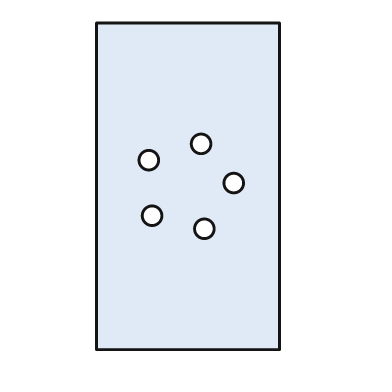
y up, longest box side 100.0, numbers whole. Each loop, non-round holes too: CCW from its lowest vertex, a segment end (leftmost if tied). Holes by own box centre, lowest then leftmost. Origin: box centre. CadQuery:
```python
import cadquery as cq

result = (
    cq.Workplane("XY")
    .moveTo(-28.0, -50.0)
    .lineTo(28.0, -50.0)
    .lineTo(28.0, 50.0)
    .lineTo(-28.0, 50.0)
    .close()
    .moveTo(5.0, -13.0)
    .circle(3.0)
    .moveTo(-11.0, -9.0)
    .circle(3.0)
    .moveTo(14.0, 1.0)
    .circle(3.0)
    .moveTo(-12.0, 8.0)
    .circle(3.0)
    .moveTo(4.0, 13.0)
    .circle(3.0)
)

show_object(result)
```